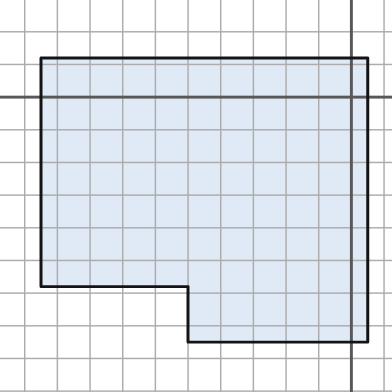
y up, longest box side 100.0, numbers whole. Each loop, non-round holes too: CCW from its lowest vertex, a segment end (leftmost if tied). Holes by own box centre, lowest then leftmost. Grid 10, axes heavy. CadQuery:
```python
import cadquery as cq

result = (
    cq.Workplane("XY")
    .moveTo(-50.0, -75.0)
    .lineTo(5.0, -75.0)
    .lineTo(5.0, 12.0)
    .lineTo(-95.0, 12.0)
    .lineTo(-95.0, -58.0)
    .lineTo(-50.0, -58.0)
    .close()
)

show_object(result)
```